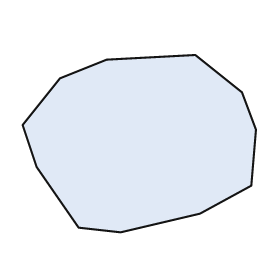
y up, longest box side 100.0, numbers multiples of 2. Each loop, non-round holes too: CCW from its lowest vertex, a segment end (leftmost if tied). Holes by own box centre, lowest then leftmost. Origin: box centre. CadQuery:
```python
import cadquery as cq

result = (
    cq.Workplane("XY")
    .moveTo(-8.0, -38.0)
    .lineTo(26.0, -30.0)
    .lineTo(48.0, -18.0)
    .lineTo(50.0, 6.0)
    .lineTo(44.0, 22.0)
    .lineTo(24.0, 38.0)
    .lineTo(-14.0, 36.0)
    .lineTo(-34.0, 28.0)
    .lineTo(-50.0, 8.0)
    .lineTo(-44.0, -10.0)
    .lineTo(-26.0, -36.0)
    .close()
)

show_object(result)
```